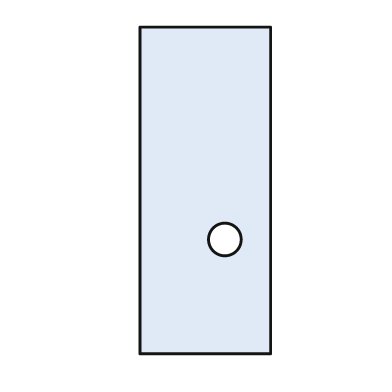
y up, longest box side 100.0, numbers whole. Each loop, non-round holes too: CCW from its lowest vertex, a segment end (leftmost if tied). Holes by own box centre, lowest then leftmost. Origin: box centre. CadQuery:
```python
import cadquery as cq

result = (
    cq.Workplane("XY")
    .moveTo(-20.0, -50.0)
    .lineTo(20.0, -50.0)
    .lineTo(20.0, 50.0)
    .lineTo(-20.0, 50.0)
    .close()
    .moveTo(6.0, -15.0)
    .circle(5.0)
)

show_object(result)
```